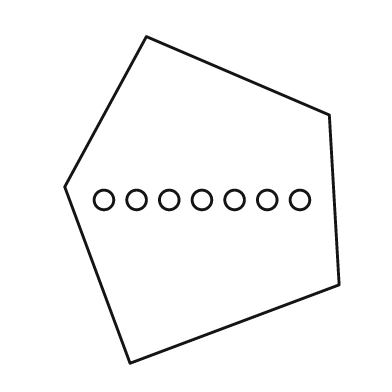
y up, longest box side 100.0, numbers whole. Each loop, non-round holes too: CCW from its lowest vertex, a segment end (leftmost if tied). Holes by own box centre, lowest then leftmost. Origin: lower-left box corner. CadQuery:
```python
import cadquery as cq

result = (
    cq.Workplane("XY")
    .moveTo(20.0, 0.0)
    .lineTo(84.0, 24.0)
    .lineTo(81.0, 76.0)
    .lineTo(25.0, 100.0)
    .lineTo(0.0, 54.0)
    .close()
    .moveTo(12.0, 50.0)
    .circle(3.0)
    .moveTo(22.0, 50.0)
    .circle(3.0)
    .moveTo(32.0, 50.0)
    .circle(3.0)
    .moveTo(42.0, 50.0)
    .circle(3.0)
    .moveTo(52.0, 50.0)
    .circle(3.0)
    .moveTo(62.0, 50.0)
    .circle(3.0)
    .moveTo(72.0, 50.0)
    .circle(3.0)
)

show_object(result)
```